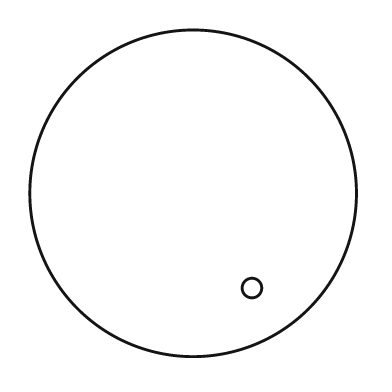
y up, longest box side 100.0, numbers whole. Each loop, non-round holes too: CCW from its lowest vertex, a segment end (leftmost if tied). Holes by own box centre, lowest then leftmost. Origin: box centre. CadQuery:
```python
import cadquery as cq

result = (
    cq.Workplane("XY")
    .moveTo(0.0, 0.0)
    .circle(50.0)
    .moveTo(18.0, -29.0)
    .circle(3.0)
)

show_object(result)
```